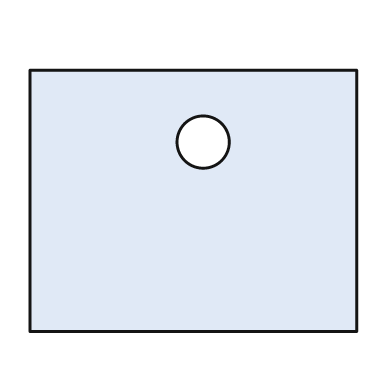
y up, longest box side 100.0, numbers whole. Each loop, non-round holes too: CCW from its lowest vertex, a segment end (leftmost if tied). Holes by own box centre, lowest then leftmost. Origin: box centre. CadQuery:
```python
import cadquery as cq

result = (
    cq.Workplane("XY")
    .moveTo(-50.0, -40.0)
    .lineTo(50.0, -40.0)
    .lineTo(50.0, 40.0)
    .lineTo(-50.0, 40.0)
    .close()
    .moveTo(3.0, 18.0)
    .circle(8.0)
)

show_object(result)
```